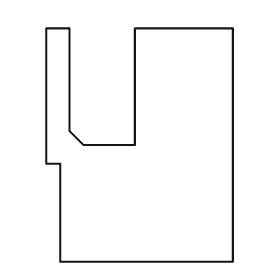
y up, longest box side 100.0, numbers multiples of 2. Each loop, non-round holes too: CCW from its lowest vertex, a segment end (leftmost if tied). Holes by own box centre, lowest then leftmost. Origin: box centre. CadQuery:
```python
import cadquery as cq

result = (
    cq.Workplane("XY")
    .moveTo(-34.0, -50.0)
    .lineTo(40.0, -50.0)
    .lineTo(40.0, 50.0)
    .lineTo(-2.0, 50.0)
    .lineTo(-2.0, 0.0)
    .lineTo(-24.0, 0.0)
    .lineTo(-30.0, 6.0)
    .lineTo(-30.0, 50.0)
    .lineTo(-40.0, 50.0)
    .lineTo(-40.0, -8.0)
    .lineTo(-34.0, -8.0)
    .close()
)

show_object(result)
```